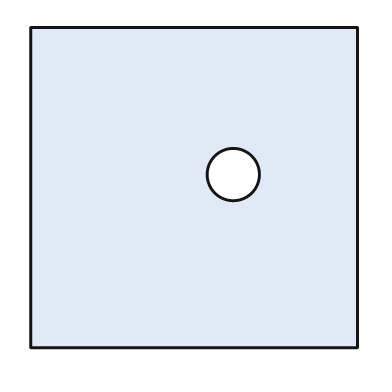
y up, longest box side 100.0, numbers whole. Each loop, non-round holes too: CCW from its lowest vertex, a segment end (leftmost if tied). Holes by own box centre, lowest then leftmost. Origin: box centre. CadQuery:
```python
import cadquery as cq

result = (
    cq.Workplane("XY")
    .moveTo(-50.0, -49.0)
    .lineTo(50.0, -49.0)
    .lineTo(50.0, 49.0)
    .lineTo(-50.0, 49.0)
    .close()
    .moveTo(12.0, 4.0)
    .circle(8.0)
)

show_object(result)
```